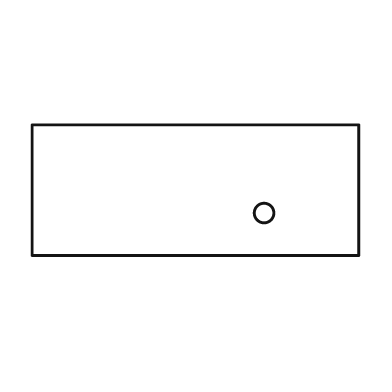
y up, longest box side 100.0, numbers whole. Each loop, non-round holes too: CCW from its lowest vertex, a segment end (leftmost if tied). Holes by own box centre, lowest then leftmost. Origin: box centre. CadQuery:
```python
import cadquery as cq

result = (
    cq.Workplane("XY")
    .moveTo(-50.0, -20.0)
    .lineTo(50.0, -20.0)
    .lineTo(50.0, 20.0)
    .lineTo(-50.0, 20.0)
    .close()
    .moveTo(21.0, -7.0)
    .circle(3.0)
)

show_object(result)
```